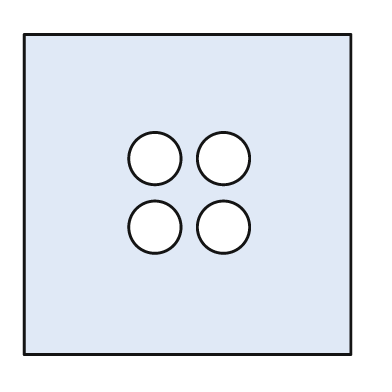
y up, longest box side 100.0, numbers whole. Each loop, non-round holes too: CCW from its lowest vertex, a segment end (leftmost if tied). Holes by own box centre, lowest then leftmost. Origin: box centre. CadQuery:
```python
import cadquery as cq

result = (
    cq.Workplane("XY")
    .moveTo(-50.0, -49.0)
    .lineTo(50.0, -49.0)
    .lineTo(50.0, 49.0)
    .lineTo(-50.0, 49.0)
    .close()
    .moveTo(-10.0, -10.0)
    .circle(8.0)
    .moveTo(11.0, -10.0)
    .circle(8.0)
    .moveTo(-10.0, 11.0)
    .circle(8.0)
    .moveTo(11.0, 11.0)
    .circle(8.0)
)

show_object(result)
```